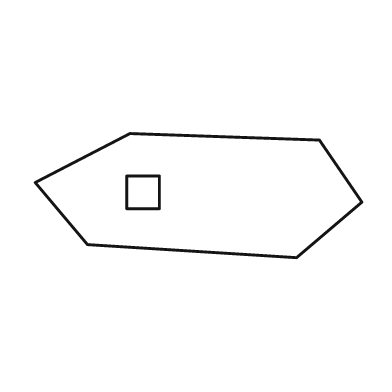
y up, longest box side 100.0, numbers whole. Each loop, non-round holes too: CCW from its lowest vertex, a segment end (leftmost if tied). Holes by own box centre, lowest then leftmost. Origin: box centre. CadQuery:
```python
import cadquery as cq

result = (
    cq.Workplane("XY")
    .moveTo(30.0, -19.0)
    .lineTo(50.0, -2.0)
    .lineTo(37.0, 17.0)
    .lineTo(-21.0, 19.0)
    .lineTo(-50.0, 4.0)
    .lineTo(-34.0, -15.0)
    .close()
    .moveTo(-22.0, -4.0)
    .lineTo(-12.0, -4.0)
    .lineTo(-12.0, 6.0)
    .lineTo(-22.0, 6.0)
    .close()
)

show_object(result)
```